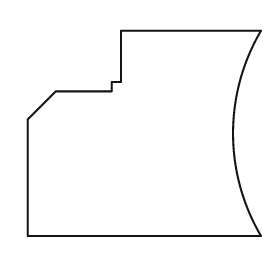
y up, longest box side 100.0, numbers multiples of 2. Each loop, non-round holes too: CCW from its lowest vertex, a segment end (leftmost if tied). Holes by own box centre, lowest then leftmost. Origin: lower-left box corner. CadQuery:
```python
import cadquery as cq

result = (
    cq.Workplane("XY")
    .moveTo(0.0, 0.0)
    .lineTo(100.0, 0.0)
    .threePointArc((88.0, 44.0), (100.0, 88.0))
    .lineTo(40.0, 88.0)
    .lineTo(40.0, 66.0)
    .lineTo(36.0, 66.0)
    .lineTo(36.0, 62.0)
    .lineTo(12.0, 62.0)
    .lineTo(0.0, 50.0)
    .close()
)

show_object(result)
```